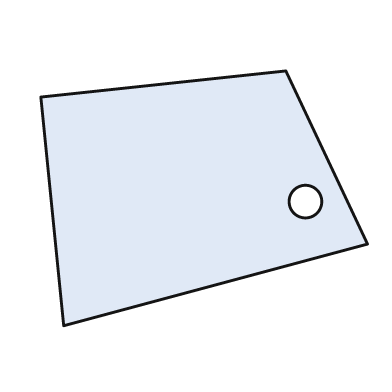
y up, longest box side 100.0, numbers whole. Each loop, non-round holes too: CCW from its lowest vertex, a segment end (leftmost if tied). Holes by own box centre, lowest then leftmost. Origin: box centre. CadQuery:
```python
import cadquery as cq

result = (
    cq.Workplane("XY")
    .moveTo(-43.0, -39.0)
    .lineTo(50.0, -14.0)
    .lineTo(25.0, 39.0)
    .lineTo(-50.0, 31.0)
    .close()
    .moveTo(31.0, -1.0)
    .circle(5.0)
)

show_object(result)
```